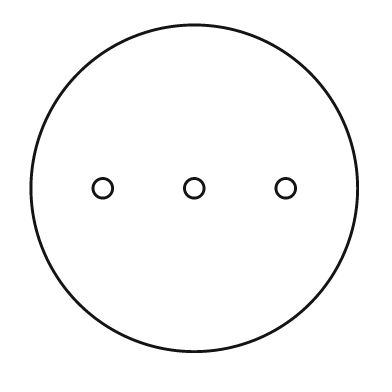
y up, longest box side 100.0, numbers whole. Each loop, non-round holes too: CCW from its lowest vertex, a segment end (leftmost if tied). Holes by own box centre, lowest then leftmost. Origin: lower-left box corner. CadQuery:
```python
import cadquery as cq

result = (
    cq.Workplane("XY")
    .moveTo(50.0, 50.0)
    .circle(50.0)
    .moveTo(22.0, 50.0)
    .circle(3.0)
    .moveTo(50.0, 50.0)
    .circle(3.0)
    .moveTo(78.0, 50.0)
    .circle(3.0)
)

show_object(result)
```